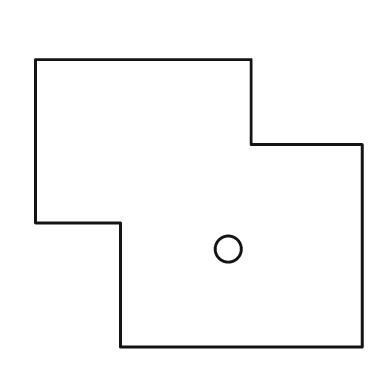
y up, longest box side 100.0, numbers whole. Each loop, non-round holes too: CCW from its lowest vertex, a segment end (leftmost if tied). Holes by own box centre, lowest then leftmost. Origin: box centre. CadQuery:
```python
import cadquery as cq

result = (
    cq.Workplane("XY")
    .moveTo(-24.0, -44.0)
    .lineTo(50.0, -44.0)
    .lineTo(50.0, 18.0)
    .lineTo(16.0, 18.0)
    .lineTo(16.0, 44.0)
    .lineTo(-50.0, 44.0)
    .lineTo(-50.0, -6.0)
    .lineTo(-24.0, -6.0)
    .close()
    .moveTo(9.0, -14.0)
    .circle(4.0)
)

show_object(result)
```